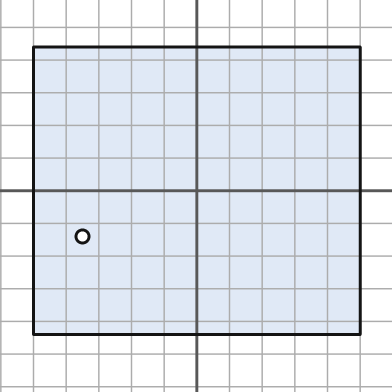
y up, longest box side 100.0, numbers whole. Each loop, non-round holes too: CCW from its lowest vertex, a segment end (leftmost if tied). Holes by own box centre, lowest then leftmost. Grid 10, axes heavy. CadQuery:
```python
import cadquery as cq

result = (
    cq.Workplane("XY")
    .moveTo(-50.0, -44.0)
    .lineTo(50.0, -44.0)
    .lineTo(50.0, 44.0)
    .lineTo(-50.0, 44.0)
    .close()
    .moveTo(-35.0, -14.0)
    .circle(2.0)
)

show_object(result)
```